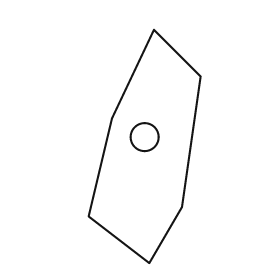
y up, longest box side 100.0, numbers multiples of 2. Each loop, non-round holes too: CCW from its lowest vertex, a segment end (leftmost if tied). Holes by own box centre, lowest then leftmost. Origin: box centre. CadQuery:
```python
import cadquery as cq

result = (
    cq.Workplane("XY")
    .moveTo(2.0, -50.0)
    .lineTo(16.0, -26.0)
    .lineTo(24.0, 30.0)
    .lineTo(4.0, 50.0)
    .lineTo(-14.0, 12.0)
    .lineTo(-24.0, -30.0)
    .close()
    .moveTo(0.0, 4.0)
    .circle(6.0)
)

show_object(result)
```